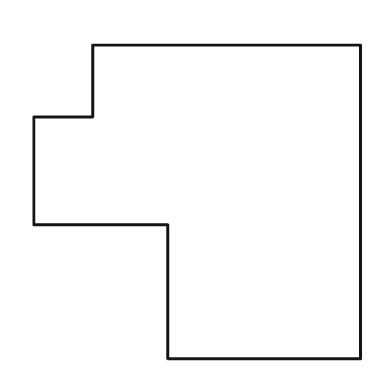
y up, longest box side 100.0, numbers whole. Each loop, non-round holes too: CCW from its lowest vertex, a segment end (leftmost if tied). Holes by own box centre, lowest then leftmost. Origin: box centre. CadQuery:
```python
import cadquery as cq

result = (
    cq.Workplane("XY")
    .moveTo(-9.0, -48.0)
    .lineTo(50.0, -48.0)
    .lineTo(50.0, 48.0)
    .lineTo(-32.0, 48.0)
    .lineTo(-32.0, 26.0)
    .lineTo(-50.0, 26.0)
    .lineTo(-50.0, -7.0)
    .lineTo(-9.0, -7.0)
    .close()
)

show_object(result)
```